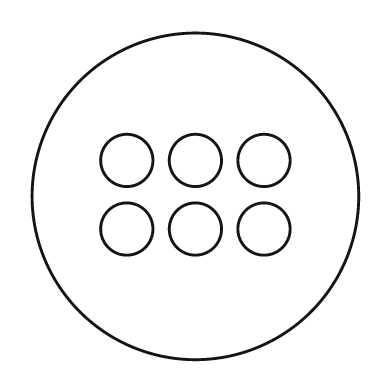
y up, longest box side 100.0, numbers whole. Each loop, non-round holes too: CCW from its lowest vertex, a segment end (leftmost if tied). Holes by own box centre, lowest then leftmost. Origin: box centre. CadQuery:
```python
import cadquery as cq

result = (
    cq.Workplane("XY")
    .moveTo(0.0, 0.0)
    .circle(50.0)
    .moveTo(-21.0, -10.0)
    .circle(8.0)
    .moveTo(0.0, -10.0)
    .circle(8.0)
    .moveTo(21.0, -10.0)
    .circle(8.0)
    .moveTo(-21.0, 11.0)
    .circle(8.0)
    .moveTo(0.0, 11.0)
    .circle(8.0)
    .moveTo(21.0, 11.0)
    .circle(8.0)
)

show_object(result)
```